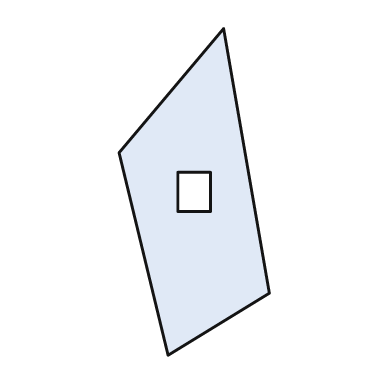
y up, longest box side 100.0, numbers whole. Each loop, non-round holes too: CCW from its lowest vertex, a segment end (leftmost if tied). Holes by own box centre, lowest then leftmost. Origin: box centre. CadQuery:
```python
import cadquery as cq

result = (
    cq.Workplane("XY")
    .moveTo(-8.0, -50.0)
    .lineTo(23.0, -31.0)
    .lineTo(9.0, 50.0)
    .lineTo(-23.0, 12.0)
    .close()
    .moveTo(-5.0, -6.0)
    .lineTo(5.0, -6.0)
    .lineTo(5.0, 6.0)
    .lineTo(-5.0, 6.0)
    .close()
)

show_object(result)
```